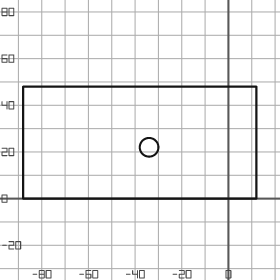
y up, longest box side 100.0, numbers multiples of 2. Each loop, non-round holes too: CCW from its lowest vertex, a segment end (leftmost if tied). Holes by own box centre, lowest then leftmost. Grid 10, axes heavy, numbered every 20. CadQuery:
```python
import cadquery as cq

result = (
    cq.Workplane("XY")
    .moveTo(-88.0, 0.0)
    .lineTo(12.0, 0.0)
    .lineTo(12.0, 48.0)
    .lineTo(-88.0, 48.0)
    .close()
    .moveTo(-34.0, 22.0)
    .circle(4.0)
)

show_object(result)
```